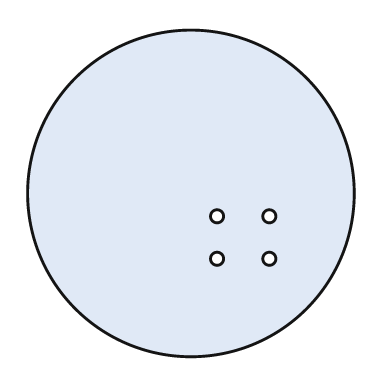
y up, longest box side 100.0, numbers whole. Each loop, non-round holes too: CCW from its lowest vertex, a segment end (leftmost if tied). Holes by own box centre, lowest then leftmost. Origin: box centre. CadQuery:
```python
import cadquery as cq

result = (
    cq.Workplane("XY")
    .moveTo(0.0, 0.0)
    .circle(50.0)
    .moveTo(8.0, -20.0)
    .circle(2.0)
    .moveTo(24.0, -20.0)
    .circle(2.0)
    .moveTo(8.0, -7.0)
    .circle(2.0)
    .moveTo(24.0, -7.0)
    .circle(2.0)
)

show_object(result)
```